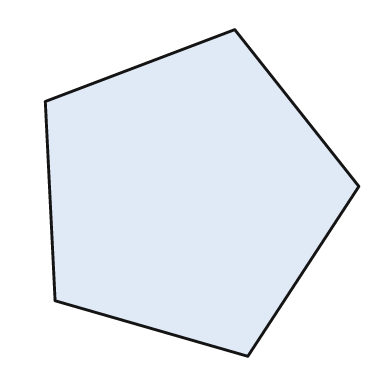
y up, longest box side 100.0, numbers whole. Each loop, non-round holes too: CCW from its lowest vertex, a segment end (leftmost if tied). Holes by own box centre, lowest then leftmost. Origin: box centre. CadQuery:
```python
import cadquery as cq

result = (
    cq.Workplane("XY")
    .moveTo(14.0, -50.0)
    .lineTo(48.0, 2.0)
    .lineTo(10.0, 50.0)
    .lineTo(-48.0, 28.0)
    .lineTo(-45.0, -33.0)
    .close()
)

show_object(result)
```